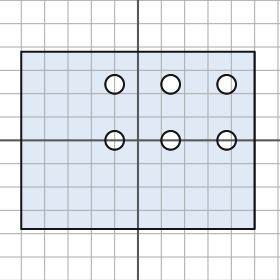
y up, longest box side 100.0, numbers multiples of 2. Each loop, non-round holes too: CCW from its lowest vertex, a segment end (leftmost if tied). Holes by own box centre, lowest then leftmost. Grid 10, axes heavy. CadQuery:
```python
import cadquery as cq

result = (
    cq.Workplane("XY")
    .moveTo(-50.0, -38.0)
    .lineTo(50.0, -38.0)
    .lineTo(50.0, 38.0)
    .lineTo(-50.0, 38.0)
    .close()
    .moveTo(-10.0, 0.0)
    .circle(4.0)
    .moveTo(14.0, 0.0)
    .circle(4.0)
    .moveTo(38.0, 0.0)
    .circle(4.0)
    .moveTo(-10.0, 24.0)
    .circle(4.0)
    .moveTo(14.0, 24.0)
    .circle(4.0)
    .moveTo(38.0, 24.0)
    .circle(4.0)
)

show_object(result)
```